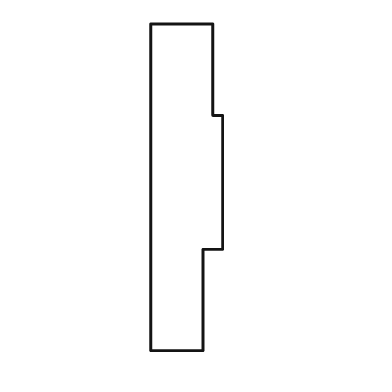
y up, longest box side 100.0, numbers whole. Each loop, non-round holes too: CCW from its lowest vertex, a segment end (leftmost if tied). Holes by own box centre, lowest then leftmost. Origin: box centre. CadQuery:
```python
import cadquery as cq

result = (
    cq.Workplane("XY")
    .moveTo(-11.0, -50.0)
    .lineTo(5.0, -50.0)
    .lineTo(5.0, -19.0)
    .lineTo(11.0, -19.0)
    .lineTo(11.0, 22.0)
    .lineTo(8.0, 22.0)
    .lineTo(8.0, 50.0)
    .lineTo(-11.0, 50.0)
    .close()
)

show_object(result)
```